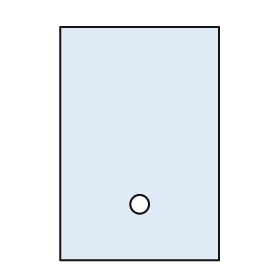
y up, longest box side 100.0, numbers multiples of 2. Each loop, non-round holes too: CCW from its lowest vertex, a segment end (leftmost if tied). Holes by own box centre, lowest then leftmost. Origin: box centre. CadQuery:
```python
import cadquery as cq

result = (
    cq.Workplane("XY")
    .moveTo(-34.0, -50.0)
    .lineTo(34.0, -50.0)
    .lineTo(34.0, 50.0)
    .lineTo(-34.0, 50.0)
    .close()
    .moveTo(0.0, -26.0)
    .circle(4.0)
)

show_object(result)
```